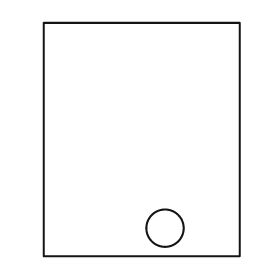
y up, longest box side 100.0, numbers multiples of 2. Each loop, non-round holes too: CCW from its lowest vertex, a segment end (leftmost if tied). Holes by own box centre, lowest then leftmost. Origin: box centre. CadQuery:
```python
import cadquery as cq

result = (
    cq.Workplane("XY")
    .moveTo(-42.0, -50.0)
    .lineTo(42.0, -50.0)
    .lineTo(42.0, 50.0)
    .lineTo(-42.0, 50.0)
    .close()
    .moveTo(10.0, -38.0)
    .circle(8.0)
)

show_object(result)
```